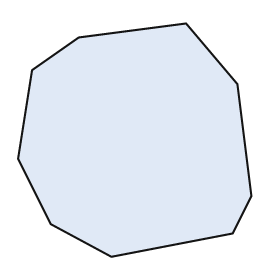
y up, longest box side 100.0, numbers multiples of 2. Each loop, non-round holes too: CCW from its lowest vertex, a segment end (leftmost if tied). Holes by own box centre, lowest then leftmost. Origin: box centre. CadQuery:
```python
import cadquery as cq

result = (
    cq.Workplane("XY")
    .moveTo(-10.0, -50.0)
    .lineTo(42.0, -40.0)
    .lineTo(50.0, -24.0)
    .lineTo(44.0, 24.0)
    .lineTo(22.0, 50.0)
    .lineTo(-24.0, 44.0)
    .lineTo(-44.0, 30.0)
    .lineTo(-50.0, -8.0)
    .lineTo(-36.0, -36.0)
    .close()
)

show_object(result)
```